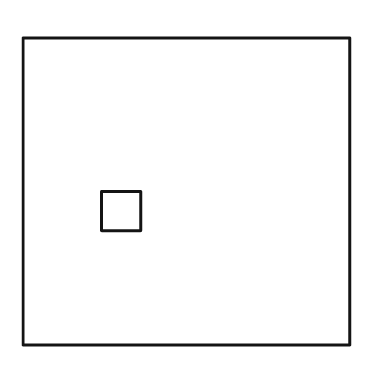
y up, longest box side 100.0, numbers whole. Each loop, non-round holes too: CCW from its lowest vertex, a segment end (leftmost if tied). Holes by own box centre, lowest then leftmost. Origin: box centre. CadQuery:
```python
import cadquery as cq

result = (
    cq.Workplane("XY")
    .moveTo(-50.0, -47.0)
    .lineTo(50.0, -47.0)
    .lineTo(50.0, 47.0)
    .lineTo(-50.0, 47.0)
    .close()
    .moveTo(-26.0, -12.0)
    .lineTo(-14.0, -12.0)
    .lineTo(-14.0, 0.0)
    .lineTo(-26.0, 0.0)
    .close()
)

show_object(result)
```